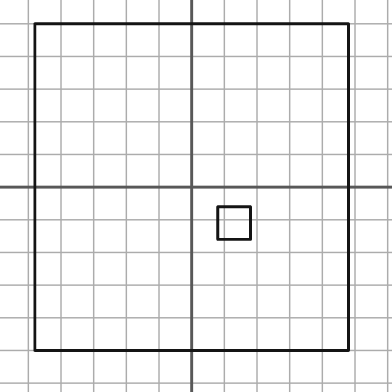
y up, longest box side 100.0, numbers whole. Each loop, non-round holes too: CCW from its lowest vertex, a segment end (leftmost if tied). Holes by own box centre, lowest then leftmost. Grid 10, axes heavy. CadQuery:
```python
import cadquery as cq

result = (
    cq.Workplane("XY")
    .moveTo(-48.0, -50.0)
    .lineTo(48.0, -50.0)
    .lineTo(48.0, 50.0)
    .lineTo(-48.0, 50.0)
    .close()
    .moveTo(8.0, -16.0)
    .lineTo(18.0, -16.0)
    .lineTo(18.0, -6.0)
    .lineTo(8.0, -6.0)
    .close()
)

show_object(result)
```